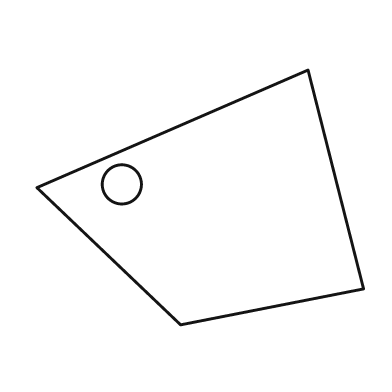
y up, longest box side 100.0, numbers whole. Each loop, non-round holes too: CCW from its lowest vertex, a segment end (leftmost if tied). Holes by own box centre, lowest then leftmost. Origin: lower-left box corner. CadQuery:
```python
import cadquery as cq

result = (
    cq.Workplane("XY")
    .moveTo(44.0, 0.0)
    .lineTo(100.0, 11.0)
    .lineTo(83.0, 78.0)
    .lineTo(0.0, 42.0)
    .close()
    .moveTo(26.0, 43.0)
    .circle(6.0)
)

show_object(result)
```